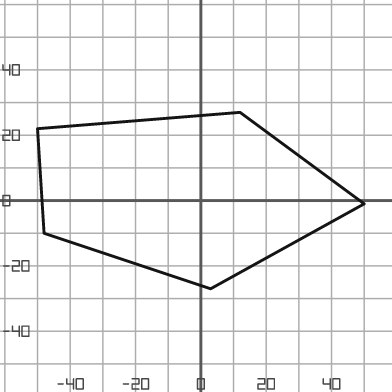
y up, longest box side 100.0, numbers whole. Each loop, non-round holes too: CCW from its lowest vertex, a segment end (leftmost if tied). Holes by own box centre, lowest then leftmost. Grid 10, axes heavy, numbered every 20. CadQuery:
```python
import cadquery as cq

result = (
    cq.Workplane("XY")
    .moveTo(3.0, -27.0)
    .lineTo(50.0, -1.0)
    .lineTo(12.0, 27.0)
    .lineTo(-50.0, 22.0)
    .lineTo(-48.0, -10.0)
    .close()
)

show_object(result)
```